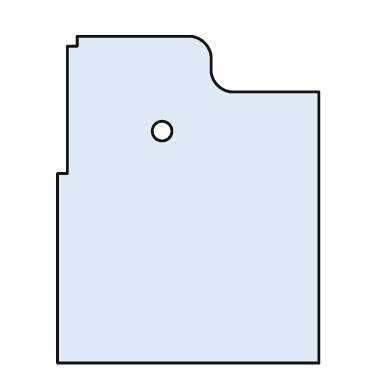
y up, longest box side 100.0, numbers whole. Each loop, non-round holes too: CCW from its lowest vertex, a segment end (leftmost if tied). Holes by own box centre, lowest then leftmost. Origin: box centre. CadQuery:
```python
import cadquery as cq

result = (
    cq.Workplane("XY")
    .moveTo(-40.0, -50.0)
    .lineTo(40.0, -50.0)
    .lineTo(40.0, 33.0)
    .lineTo(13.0, 33.0)
    .threePointArc((9.0, 35.0), (7.0, 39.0))
    .lineTo(7.0, 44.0)
    .threePointArc((5.0, 48.0), (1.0, 50.0))
    .lineTo(-34.0, 50.0)
    .lineTo(-34.0, 47.0)
    .lineTo(-37.0, 47.0)
    .lineTo(-37.0, 8.0)
    .lineTo(-40.0, 8.0)
    .close()
    .moveTo(-8.0, 21.0)
    .circle(3.0)
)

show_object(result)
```